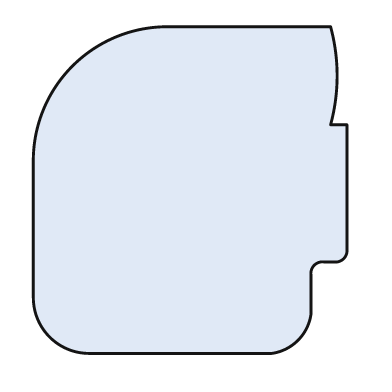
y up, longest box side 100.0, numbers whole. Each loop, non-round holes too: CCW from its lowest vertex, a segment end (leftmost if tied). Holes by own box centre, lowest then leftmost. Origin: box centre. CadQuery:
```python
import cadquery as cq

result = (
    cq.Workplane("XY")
    .moveTo(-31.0, -50.0)
    .lineTo(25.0, -50.0)
    .threePointArc((33.0, -46.0), (37.0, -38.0))
    .lineTo(37.0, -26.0)
    .threePointArc((38.0, -23.0), (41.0, -22.0))
    .lineTo(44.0, -22.0)
    .threePointArc((47.0, -21.0), (48.0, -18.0))
    .lineTo(48.0, 20.0)
    .lineTo(43.0, 20.0)
    .threePointArc((45.0, 35.0), (43.0, 50.0))
    .lineTo(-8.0, 50.0)
    .threePointArc((-36.0, 38.0), (-48.0, 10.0))
    .lineTo(-48.0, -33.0)
    .threePointArc((-43.0, -45.0), (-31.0, -50.0))
    .close()
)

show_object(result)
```